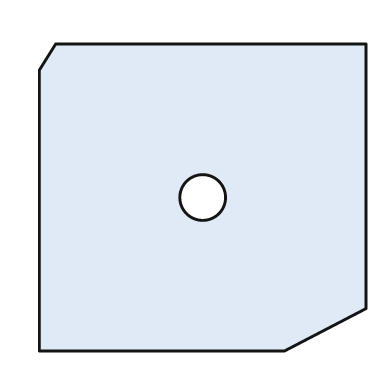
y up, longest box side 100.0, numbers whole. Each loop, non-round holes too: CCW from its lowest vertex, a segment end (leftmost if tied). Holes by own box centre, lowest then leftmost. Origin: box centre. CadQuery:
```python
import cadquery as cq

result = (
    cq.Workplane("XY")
    .moveTo(-50.0, -47.0)
    .lineTo(25.0, -47.0)
    .lineTo(50.0, -34.0)
    .lineTo(50.0, 47.0)
    .lineTo(-45.0, 47.0)
    .lineTo(-50.0, 39.0)
    .close()
    .moveTo(0.0, 0.0)
    .circle(7.0)
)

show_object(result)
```